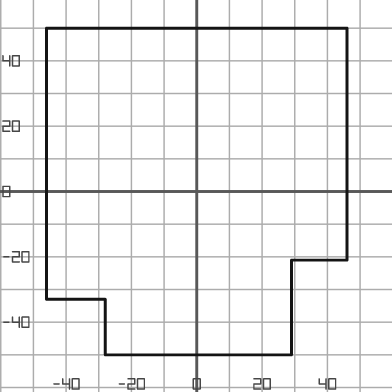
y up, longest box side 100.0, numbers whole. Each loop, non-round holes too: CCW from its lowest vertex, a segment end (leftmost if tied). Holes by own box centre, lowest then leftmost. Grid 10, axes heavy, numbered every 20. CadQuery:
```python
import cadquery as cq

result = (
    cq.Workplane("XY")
    .moveTo(-28.0, -50.0)
    .lineTo(29.0, -50.0)
    .lineTo(29.0, -21.0)
    .lineTo(46.0, -21.0)
    .lineTo(46.0, 50.0)
    .lineTo(-46.0, 50.0)
    .lineTo(-46.0, -33.0)
    .lineTo(-28.0, -33.0)
    .close()
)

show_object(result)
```